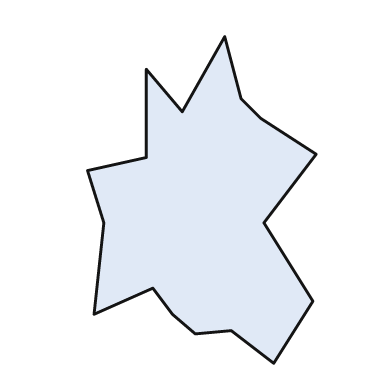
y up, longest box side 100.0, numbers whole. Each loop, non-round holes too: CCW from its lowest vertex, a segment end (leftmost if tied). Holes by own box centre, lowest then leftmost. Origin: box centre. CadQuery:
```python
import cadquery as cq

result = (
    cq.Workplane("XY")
    .moveTo(22.0, -50.0)
    .lineTo(34.0, -31.0)
    .lineTo(19.0, -7.0)
    .lineTo(35.0, 14.0)
    .lineTo(18.0, 25.0)
    .lineTo(12.0, 31.0)
    .lineTo(7.0, 50.0)
    .lineTo(-6.0, 27.0)
    .lineTo(-17.0, 40.0)
    .lineTo(-17.0, 13.0)
    .lineTo(-35.0, 9.0)
    .lineTo(-30.0, -7.0)
    .lineTo(-33.0, -35.0)
    .lineTo(-15.0, -27.0)
    .lineTo(-9.0, -35.0)
    .lineTo(-2.0, -41.0)
    .lineTo(9.0, -40.0)
    .close()
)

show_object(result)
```